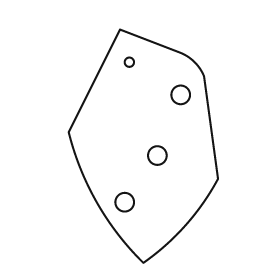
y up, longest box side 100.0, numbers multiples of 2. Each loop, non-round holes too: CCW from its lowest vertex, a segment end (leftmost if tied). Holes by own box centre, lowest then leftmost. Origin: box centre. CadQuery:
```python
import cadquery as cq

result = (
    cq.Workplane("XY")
    .moveTo(0.0, -50.0)
    .threePointArc((18.0, -34.0), (32.0, -14.0))
    .lineTo(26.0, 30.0)
    .threePointArc((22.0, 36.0), (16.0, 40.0))
    .lineTo(-10.0, 50.0)
    .lineTo(-32.0, 6.0)
    .threePointArc((-20.0, -24.0), (0.0, -50.0))
    .close()
    .moveTo(-8.0, -24.0)
    .circle(4.0)
    .moveTo(6.0, -4.0)
    .circle(4.0)
    .moveTo(16.0, 22.0)
    .circle(4.0)
    .moveTo(-6.0, 36.0)
    .circle(2.0)
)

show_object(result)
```